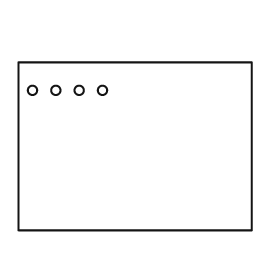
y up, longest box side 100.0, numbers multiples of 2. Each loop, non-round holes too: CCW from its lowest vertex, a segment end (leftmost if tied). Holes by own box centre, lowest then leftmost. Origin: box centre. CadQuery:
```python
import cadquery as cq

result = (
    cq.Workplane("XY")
    .moveTo(-50.0, -36.0)
    .lineTo(50.0, -36.0)
    .lineTo(50.0, 36.0)
    .lineTo(-50.0, 36.0)
    .close()
    .moveTo(-44.0, 24.0)
    .circle(2.0)
    .moveTo(-34.0, 24.0)
    .circle(2.0)
    .moveTo(-24.0, 24.0)
    .circle(2.0)
    .moveTo(-14.0, 24.0)
    .circle(2.0)
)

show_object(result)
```